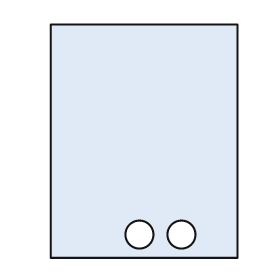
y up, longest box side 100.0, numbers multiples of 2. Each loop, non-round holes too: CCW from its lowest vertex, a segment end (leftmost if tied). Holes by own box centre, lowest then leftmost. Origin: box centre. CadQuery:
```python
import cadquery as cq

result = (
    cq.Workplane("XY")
    .moveTo(-40.0, -50.0)
    .lineTo(40.0, -50.0)
    .lineTo(40.0, 50.0)
    .lineTo(-40.0, 50.0)
    .close()
    .moveTo(-2.0, -40.0)
    .circle(6.0)
    .moveTo(16.0, -40.0)
    .circle(6.0)
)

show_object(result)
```